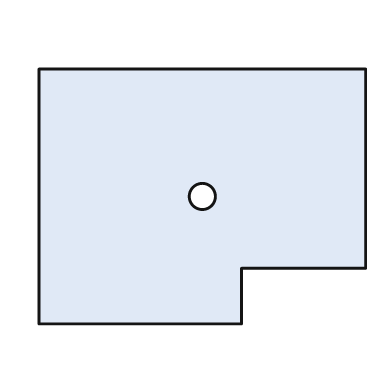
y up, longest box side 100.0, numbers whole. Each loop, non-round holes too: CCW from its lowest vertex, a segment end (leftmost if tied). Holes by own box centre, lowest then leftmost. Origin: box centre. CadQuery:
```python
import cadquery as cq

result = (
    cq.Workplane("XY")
    .moveTo(-50.0, -39.0)
    .lineTo(12.0, -39.0)
    .lineTo(12.0, -22.0)
    .lineTo(50.0, -22.0)
    .lineTo(50.0, 39.0)
    .lineTo(-50.0, 39.0)
    .close()
    .moveTo(0.0, 0.0)
    .circle(4.0)
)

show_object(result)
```